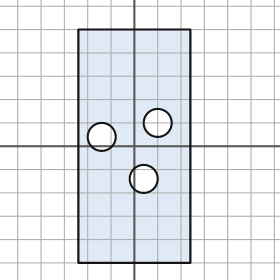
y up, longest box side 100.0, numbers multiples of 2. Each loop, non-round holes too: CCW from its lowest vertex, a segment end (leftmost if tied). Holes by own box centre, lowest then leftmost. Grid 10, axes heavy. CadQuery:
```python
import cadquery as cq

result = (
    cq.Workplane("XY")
    .moveTo(-24.0, -50.0)
    .lineTo(24.0, -50.0)
    .lineTo(24.0, 50.0)
    .lineTo(-24.0, 50.0)
    .close()
    .moveTo(4.0, -14.0)
    .circle(6.0)
    .moveTo(-14.0, 4.0)
    .circle(6.0)
    .moveTo(10.0, 10.0)
    .circle(6.0)
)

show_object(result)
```